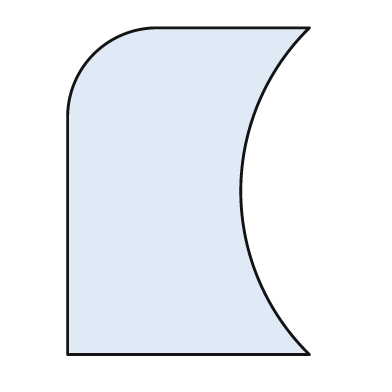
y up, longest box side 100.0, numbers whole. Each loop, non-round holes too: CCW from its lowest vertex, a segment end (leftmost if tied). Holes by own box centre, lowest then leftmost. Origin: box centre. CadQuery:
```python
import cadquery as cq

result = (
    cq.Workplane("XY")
    .moveTo(-37.0, -50.0)
    .lineTo(37.0, -50.0)
    .threePointArc((16.0, 0.0), (37.0, 50.0))
    .lineTo(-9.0, 50.0)
    .threePointArc((-29.0, 42.0), (-37.0, 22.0))
    .close()
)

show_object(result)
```